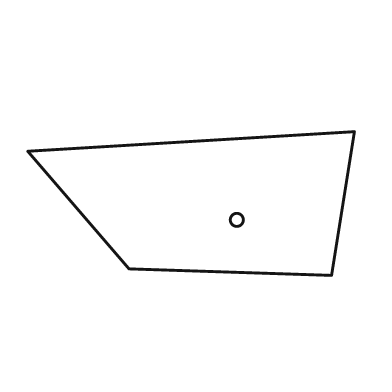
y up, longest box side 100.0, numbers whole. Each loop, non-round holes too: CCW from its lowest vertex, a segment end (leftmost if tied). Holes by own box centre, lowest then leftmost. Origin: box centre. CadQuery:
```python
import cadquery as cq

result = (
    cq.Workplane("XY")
    .moveTo(43.0, -22.0)
    .lineTo(50.0, 22.0)
    .lineTo(-50.0, 16.0)
    .lineTo(-19.0, -20.0)
    .close()
    .moveTo(14.0, -5.0)
    .circle(2.0)
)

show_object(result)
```